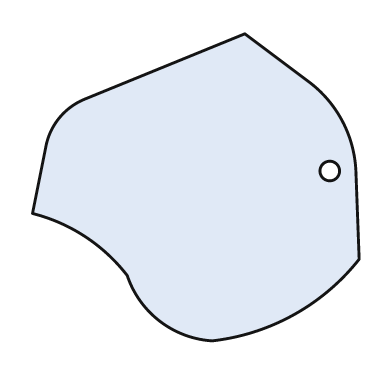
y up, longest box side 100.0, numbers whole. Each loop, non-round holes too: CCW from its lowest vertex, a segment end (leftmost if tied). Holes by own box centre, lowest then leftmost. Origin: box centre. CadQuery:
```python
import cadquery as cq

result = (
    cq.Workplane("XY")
    .moveTo(5.0, -47.0)
    .threePointArc((30.0, -39.0), (50.0, -22.0))
    .lineTo(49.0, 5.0)
    .threePointArc((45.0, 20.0), (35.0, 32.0))
    .lineTo(15.0, 47.0)
    .lineTo(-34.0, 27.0)
    .threePointArc((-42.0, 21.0), (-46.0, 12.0))
    .lineTo(-50.0, -8.0)
    .threePointArc((-34.0, -15.0), (-21.0, -27.0))
    .threePointArc((-11.0, -41.0), (5.0, -47.0))
    .close()
    .moveTo(41.0, 5.0)
    .circle(3.0)
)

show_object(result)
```